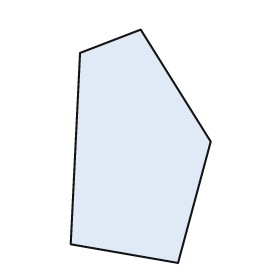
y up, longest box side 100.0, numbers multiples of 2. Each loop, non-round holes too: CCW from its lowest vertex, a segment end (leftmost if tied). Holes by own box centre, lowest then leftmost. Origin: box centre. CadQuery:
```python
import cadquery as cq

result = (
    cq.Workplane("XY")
    .moveTo(16.0, -50.0)
    .lineTo(30.0, 2.0)
    .lineTo(0.0, 50.0)
    .lineTo(-26.0, 40.0)
    .lineTo(-30.0, -42.0)
    .close()
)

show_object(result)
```